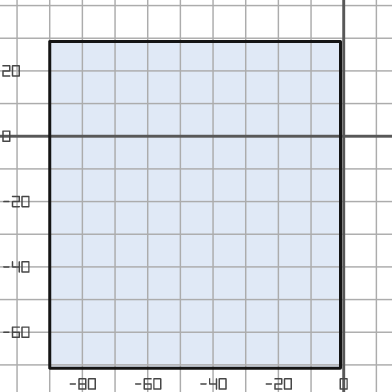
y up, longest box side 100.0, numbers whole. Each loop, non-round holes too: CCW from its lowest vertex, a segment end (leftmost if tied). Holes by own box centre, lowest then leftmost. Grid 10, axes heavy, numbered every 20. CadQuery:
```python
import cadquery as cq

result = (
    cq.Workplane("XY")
    .moveTo(-90.0, -71.0)
    .lineTo(-1.0, -71.0)
    .lineTo(-1.0, 29.0)
    .lineTo(-90.0, 29.0)
    .close()
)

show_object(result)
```